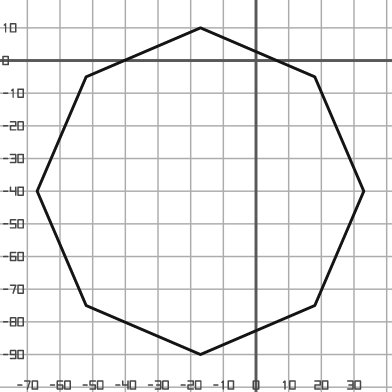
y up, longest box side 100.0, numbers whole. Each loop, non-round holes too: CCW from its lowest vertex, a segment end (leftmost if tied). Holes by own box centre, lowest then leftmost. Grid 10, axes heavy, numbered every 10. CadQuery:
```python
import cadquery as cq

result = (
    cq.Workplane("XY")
    .moveTo(-17.0, -90.0)
    .lineTo(18.0, -75.0)
    .lineTo(33.0, -40.0)
    .lineTo(18.0, -5.0)
    .lineTo(-17.0, 10.0)
    .lineTo(-52.0, -5.0)
    .lineTo(-67.0, -40.0)
    .lineTo(-52.0, -75.0)
    .close()
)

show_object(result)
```